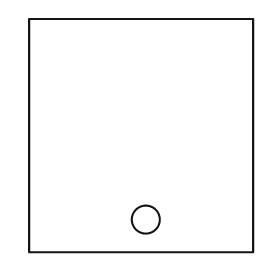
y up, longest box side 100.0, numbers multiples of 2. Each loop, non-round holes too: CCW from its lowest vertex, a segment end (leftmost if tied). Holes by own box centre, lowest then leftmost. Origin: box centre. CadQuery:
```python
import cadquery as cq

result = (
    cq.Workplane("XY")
    .moveTo(-48.0, -50.0)
    .lineTo(48.0, -50.0)
    .lineTo(48.0, 50.0)
    .lineTo(-48.0, 50.0)
    .close()
    .moveTo(2.0, -36.0)
    .circle(6.0)
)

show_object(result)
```